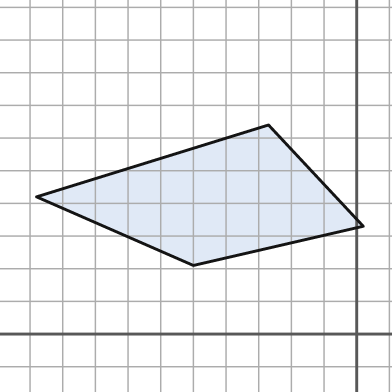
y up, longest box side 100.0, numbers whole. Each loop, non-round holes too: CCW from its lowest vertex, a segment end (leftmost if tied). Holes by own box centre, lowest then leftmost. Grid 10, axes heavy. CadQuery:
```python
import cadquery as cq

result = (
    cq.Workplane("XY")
    .moveTo(-50.0, 21.0)
    .lineTo(2.0, 33.0)
    .lineTo(-27.0, 64.0)
    .lineTo(-98.0, 42.0)
    .close()
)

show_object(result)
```